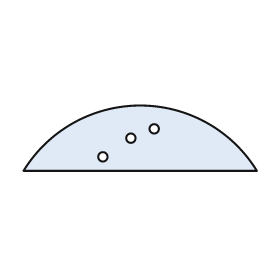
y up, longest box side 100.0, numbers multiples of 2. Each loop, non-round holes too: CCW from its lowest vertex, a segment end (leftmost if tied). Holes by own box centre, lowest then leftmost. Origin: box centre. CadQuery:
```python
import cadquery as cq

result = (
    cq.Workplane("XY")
    .moveTo(-50.0, -14.0)
    .lineTo(50.0, -14.0)
    .threePointArc((0.0, 14.0), (-50.0, -14.0))
    .close()
    .moveTo(-16.0, -8.0)
    .circle(2.0)
    .moveTo(-4.0, 0.0)
    .circle(2.0)
    .moveTo(6.0, 4.0)
    .circle(2.0)
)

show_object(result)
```